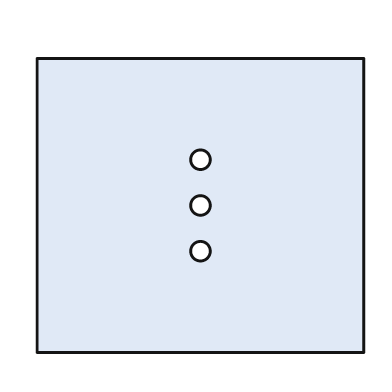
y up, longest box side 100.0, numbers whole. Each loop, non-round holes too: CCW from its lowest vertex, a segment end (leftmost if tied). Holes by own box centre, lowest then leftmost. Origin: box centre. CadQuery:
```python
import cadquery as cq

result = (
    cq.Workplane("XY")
    .moveTo(-50.0, -45.0)
    .lineTo(50.0, -45.0)
    .lineTo(50.0, 45.0)
    .lineTo(-50.0, 45.0)
    .close()
    .moveTo(0.0, -14.0)
    .circle(3.0)
    .moveTo(0.0, 0.0)
    .circle(3.0)
    .moveTo(0.0, 14.0)
    .circle(3.0)
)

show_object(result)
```